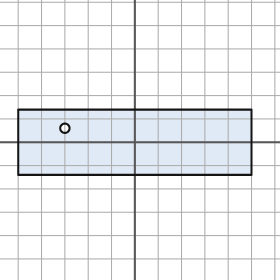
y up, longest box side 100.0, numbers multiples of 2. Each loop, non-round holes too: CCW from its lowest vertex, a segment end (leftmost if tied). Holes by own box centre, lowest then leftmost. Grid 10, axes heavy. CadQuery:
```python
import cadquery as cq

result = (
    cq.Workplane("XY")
    .moveTo(-50.0, -14.0)
    .lineTo(50.0, -14.0)
    .lineTo(50.0, 14.0)
    .lineTo(-50.0, 14.0)
    .close()
    .moveTo(-30.0, 6.0)
    .circle(2.0)
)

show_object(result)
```